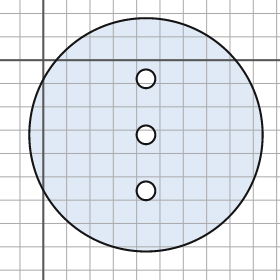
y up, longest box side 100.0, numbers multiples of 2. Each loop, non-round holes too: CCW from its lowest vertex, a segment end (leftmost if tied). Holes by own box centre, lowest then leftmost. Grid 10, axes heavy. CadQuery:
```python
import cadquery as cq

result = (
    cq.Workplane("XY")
    .moveTo(44.0, -32.0)
    .circle(50.0)
    .moveTo(44.0, -56.0)
    .circle(4.0)
    .moveTo(44.0, -32.0)
    .circle(4.0)
    .moveTo(44.0, -8.0)
    .circle(4.0)
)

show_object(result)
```